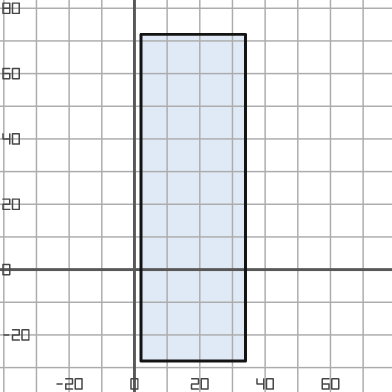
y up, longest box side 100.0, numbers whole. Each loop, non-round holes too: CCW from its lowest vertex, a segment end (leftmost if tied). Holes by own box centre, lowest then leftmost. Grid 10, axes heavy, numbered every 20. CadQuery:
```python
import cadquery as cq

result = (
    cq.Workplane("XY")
    .moveTo(2.0, -28.0)
    .lineTo(34.0, -28.0)
    .lineTo(34.0, 72.0)
    .lineTo(2.0, 72.0)
    .close()
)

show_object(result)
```